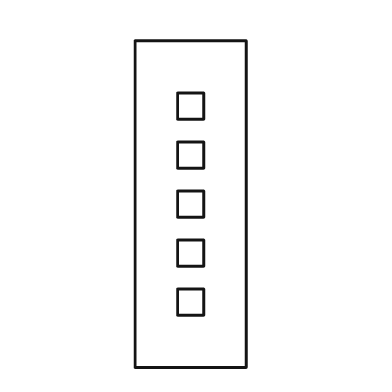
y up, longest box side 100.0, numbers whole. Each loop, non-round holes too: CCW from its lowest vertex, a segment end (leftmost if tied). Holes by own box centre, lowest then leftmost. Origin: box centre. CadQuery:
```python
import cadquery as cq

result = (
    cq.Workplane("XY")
    .moveTo(-17.0, -50.0)
    .lineTo(17.0, -50.0)
    .lineTo(17.0, 50.0)
    .lineTo(-17.0, 50.0)
    .close()
    .moveTo(-4.0, -34.0)
    .lineTo(4.0, -34.0)
    .lineTo(4.0, -26.0)
    .lineTo(-4.0, -26.0)
    .close()
    .moveTo(-4.0, -19.0)
    .lineTo(4.0, -19.0)
    .lineTo(4.0, -11.0)
    .lineTo(-4.0, -11.0)
    .close()
    .moveTo(-4.0, -4.0)
    .lineTo(4.0, -4.0)
    .lineTo(4.0, 4.0)
    .lineTo(-4.0, 4.0)
    .close()
    .moveTo(-4.0, 11.0)
    .lineTo(4.0, 11.0)
    .lineTo(4.0, 19.0)
    .lineTo(-4.0, 19.0)
    .close()
    .moveTo(-4.0, 26.0)
    .lineTo(4.0, 26.0)
    .lineTo(4.0, 34.0)
    .lineTo(-4.0, 34.0)
    .close()
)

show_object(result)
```